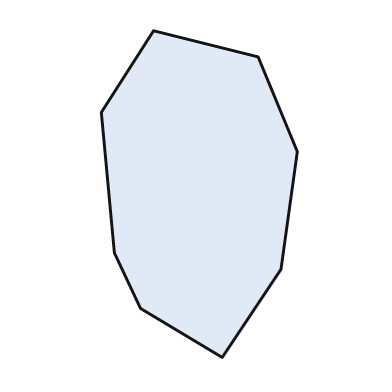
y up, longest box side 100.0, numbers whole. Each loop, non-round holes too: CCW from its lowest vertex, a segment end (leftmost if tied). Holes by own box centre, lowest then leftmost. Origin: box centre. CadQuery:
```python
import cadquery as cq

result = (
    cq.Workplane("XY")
    .moveTo(7.0, -50.0)
    .lineTo(25.0, -23.0)
    .lineTo(30.0, 13.0)
    .lineTo(18.0, 42.0)
    .lineTo(-14.0, 50.0)
    .lineTo(-30.0, 25.0)
    .lineTo(-26.0, -18.0)
    .lineTo(-18.0, -35.0)
    .close()
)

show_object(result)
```